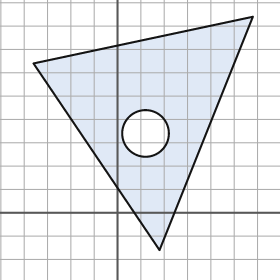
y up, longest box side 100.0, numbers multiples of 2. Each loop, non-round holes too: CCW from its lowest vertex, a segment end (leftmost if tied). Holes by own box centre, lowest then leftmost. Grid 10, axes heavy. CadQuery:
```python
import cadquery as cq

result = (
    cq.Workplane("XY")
    .moveTo(18.0, -16.0)
    .lineTo(58.0, 84.0)
    .lineTo(-36.0, 64.0)
    .close()
    .moveTo(12.0, 34.0)
    .circle(10.0)
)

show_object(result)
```